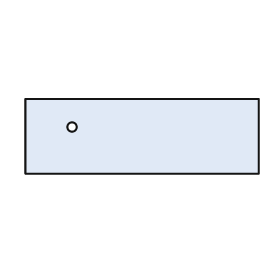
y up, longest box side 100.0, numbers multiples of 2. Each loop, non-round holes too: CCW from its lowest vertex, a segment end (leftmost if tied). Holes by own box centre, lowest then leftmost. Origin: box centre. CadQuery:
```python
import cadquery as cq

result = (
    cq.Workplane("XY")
    .moveTo(-50.0, -16.0)
    .lineTo(50.0, -16.0)
    .lineTo(50.0, 16.0)
    .lineTo(-50.0, 16.0)
    .close()
    .moveTo(-30.0, 4.0)
    .circle(2.0)
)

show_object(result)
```